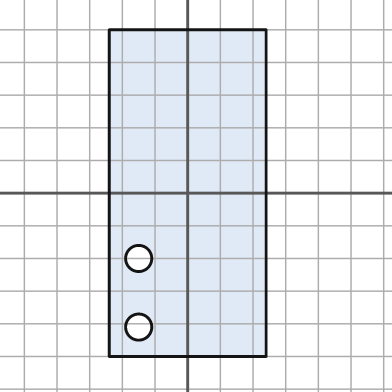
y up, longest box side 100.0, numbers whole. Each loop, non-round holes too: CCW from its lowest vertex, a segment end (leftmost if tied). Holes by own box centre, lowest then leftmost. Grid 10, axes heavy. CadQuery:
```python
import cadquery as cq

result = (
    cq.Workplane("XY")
    .moveTo(-24.0, -50.0)
    .lineTo(24.0, -50.0)
    .lineTo(24.0, 50.0)
    .lineTo(-24.0, 50.0)
    .close()
    .moveTo(-15.0, -41.0)
    .circle(4.0)
    .moveTo(-15.0, -20.0)
    .circle(4.0)
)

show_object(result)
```